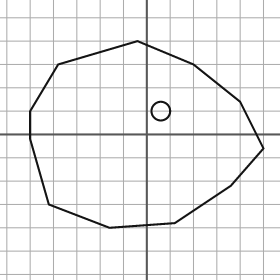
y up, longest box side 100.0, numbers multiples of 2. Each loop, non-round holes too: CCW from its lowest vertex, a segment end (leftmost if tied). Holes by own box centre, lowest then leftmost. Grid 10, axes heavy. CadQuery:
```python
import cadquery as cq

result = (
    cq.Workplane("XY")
    .moveTo(-16.0, -40.0)
    .lineTo(12.0, -38.0)
    .lineTo(36.0, -22.0)
    .lineTo(50.0, -6.0)
    .lineTo(40.0, 14.0)
    .lineTo(20.0, 30.0)
    .lineTo(-4.0, 40.0)
    .lineTo(-38.0, 30.0)
    .lineTo(-50.0, 10.0)
    .lineTo(-50.0, -2.0)
    .lineTo(-42.0, -30.0)
    .close()
    .moveTo(6.0, 10.0)
    .circle(4.0)
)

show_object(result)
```